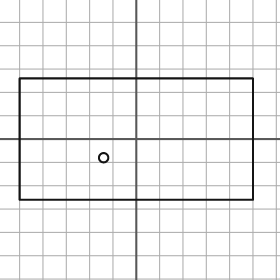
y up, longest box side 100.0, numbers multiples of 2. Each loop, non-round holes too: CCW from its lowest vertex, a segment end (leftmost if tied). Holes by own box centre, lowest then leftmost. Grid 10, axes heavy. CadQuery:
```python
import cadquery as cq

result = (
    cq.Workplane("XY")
    .moveTo(-50.0, -26.0)
    .lineTo(50.0, -26.0)
    .lineTo(50.0, 26.0)
    .lineTo(-50.0, 26.0)
    .close()
    .moveTo(-14.0, -8.0)
    .circle(2.0)
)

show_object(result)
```